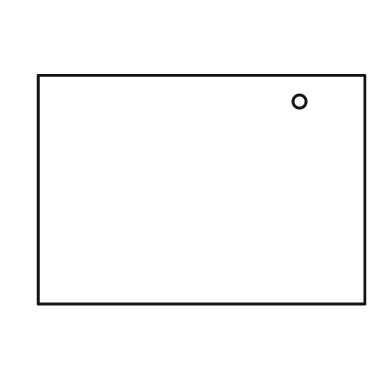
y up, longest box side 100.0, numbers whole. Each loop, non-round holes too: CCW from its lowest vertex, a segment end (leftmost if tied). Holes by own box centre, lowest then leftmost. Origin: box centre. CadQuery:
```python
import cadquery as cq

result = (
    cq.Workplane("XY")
    .moveTo(-50.0, -35.0)
    .lineTo(50.0, -35.0)
    .lineTo(50.0, 35.0)
    .lineTo(-50.0, 35.0)
    .close()
    .moveTo(30.0, 27.0)
    .circle(2.0)
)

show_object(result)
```